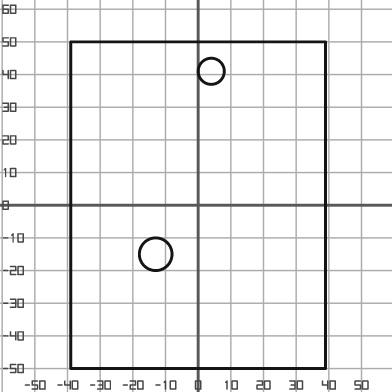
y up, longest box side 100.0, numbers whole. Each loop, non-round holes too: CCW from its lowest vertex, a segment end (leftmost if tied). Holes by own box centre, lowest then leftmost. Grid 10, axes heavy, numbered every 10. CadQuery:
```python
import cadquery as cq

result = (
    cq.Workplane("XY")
    .moveTo(-39.0, -50.0)
    .lineTo(39.0, -50.0)
    .lineTo(39.0, 50.0)
    .lineTo(-39.0, 50.0)
    .close()
    .moveTo(-13.0, -15.0)
    .circle(5.0)
    .moveTo(4.0, 41.0)
    .circle(4.0)
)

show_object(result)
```